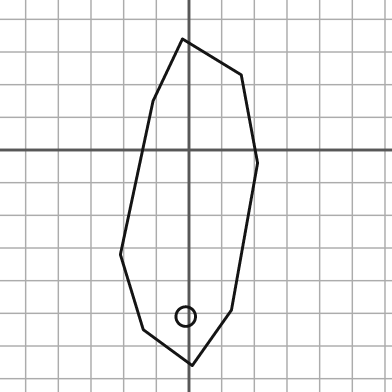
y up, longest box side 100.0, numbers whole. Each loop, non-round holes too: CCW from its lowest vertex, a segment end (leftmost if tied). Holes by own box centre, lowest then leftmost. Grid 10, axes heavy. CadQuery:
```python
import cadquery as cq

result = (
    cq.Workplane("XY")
    .moveTo(1.0, -66.0)
    .lineTo(13.0, -49.0)
    .lineTo(21.0, -4.0)
    .lineTo(16.0, 23.0)
    .lineTo(-2.0, 34.0)
    .lineTo(-11.0, 15.0)
    .lineTo(-21.0, -32.0)
    .lineTo(-14.0, -55.0)
    .close()
    .moveTo(-1.0, -51.0)
    .circle(3.0)
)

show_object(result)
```